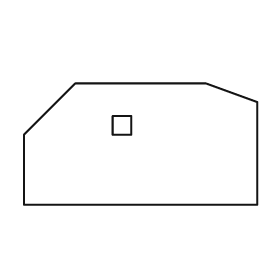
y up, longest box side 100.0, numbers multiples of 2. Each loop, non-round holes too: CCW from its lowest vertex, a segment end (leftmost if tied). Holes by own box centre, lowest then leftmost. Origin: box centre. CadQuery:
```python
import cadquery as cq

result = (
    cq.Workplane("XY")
    .moveTo(-50.0, -26.0)
    .lineTo(50.0, -26.0)
    .lineTo(50.0, 18.0)
    .lineTo(28.0, 26.0)
    .lineTo(-28.0, 26.0)
    .lineTo(-50.0, 4.0)
    .close()
    .moveTo(-12.0, 4.0)
    .lineTo(-4.0, 4.0)
    .lineTo(-4.0, 12.0)
    .lineTo(-12.0, 12.0)
    .close()
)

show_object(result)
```